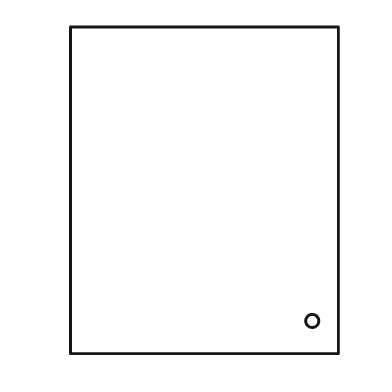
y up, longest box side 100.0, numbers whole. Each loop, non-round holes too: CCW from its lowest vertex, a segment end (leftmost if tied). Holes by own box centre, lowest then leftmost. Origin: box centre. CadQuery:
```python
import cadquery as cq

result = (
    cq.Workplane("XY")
    .moveTo(-41.0, -50.0)
    .lineTo(41.0, -50.0)
    .lineTo(41.0, 50.0)
    .lineTo(-41.0, 50.0)
    .close()
    .moveTo(33.0, -40.0)
    .circle(2.0)
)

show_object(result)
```